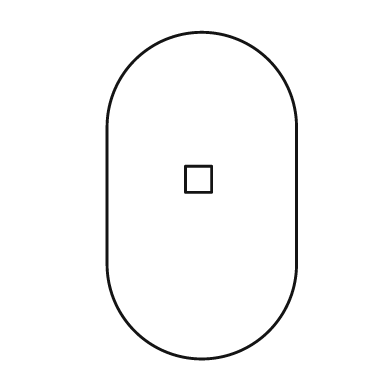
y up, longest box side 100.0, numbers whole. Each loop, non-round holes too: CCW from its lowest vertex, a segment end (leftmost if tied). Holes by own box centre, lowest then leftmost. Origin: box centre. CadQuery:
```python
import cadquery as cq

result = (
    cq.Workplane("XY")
    .moveTo(-29.0, -21.0)
    .threePointArc((0.0, -50.0), (29.0, -21.0))
    .lineTo(29.0, 21.0)
    .threePointArc((0.0, 50.0), (-29.0, 21.0))
    .close()
    .moveTo(-5.0, 1.0)
    .lineTo(3.0, 1.0)
    .lineTo(3.0, 9.0)
    .lineTo(-5.0, 9.0)
    .close()
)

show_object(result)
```